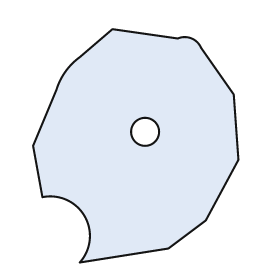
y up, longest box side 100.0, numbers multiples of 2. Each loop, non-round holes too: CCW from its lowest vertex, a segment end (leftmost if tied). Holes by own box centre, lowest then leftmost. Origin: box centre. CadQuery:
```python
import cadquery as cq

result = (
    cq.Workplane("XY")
    .moveTo(-24.0, -50.0)
    .lineTo(14.0, -44.0)
    .lineTo(30.0, -32.0)
    .lineTo(44.0, -6.0)
    .lineTo(42.0, 22.0)
    .lineTo(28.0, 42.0)
    .threePointArc((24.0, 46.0), (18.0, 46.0))
    .lineTo(-10.0, 50.0)
    .lineTo(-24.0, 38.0)
    .threePointArc((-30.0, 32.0), (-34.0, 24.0))
    .lineTo(-44.0, 0.0)
    .lineTo(-40.0, -22.0)
    .threePointArc((-22.0, -30.0), (-24.0, -50.0))
    .close()
    .moveTo(4.0, 6.0)
    .circle(6.0)
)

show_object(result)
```